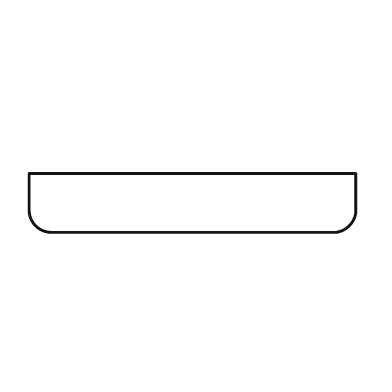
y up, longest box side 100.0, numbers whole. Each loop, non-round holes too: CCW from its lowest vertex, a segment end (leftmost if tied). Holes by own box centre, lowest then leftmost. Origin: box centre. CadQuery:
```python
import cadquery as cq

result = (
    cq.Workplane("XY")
    .moveTo(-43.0, -9.0)
    .lineTo(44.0, -9.0)
    .threePointArc((48.0, -7.0), (50.0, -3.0))
    .lineTo(50.0, 9.0)
    .lineTo(-50.0, 9.0)
    .lineTo(-50.0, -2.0)
    .threePointArc((-48.0, -7.0), (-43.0, -9.0))
    .close()
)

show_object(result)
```